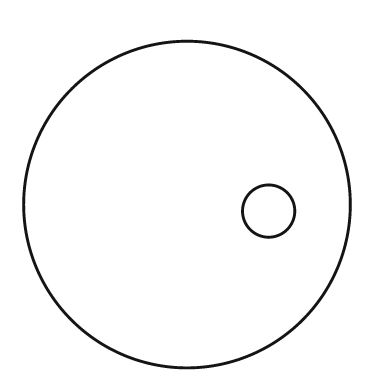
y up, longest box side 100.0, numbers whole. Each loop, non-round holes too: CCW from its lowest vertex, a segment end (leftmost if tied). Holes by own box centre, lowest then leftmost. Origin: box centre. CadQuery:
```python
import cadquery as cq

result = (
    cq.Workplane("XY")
    .moveTo(0.0, 0.0)
    .circle(50.0)
    .moveTo(25.0, -2.0)
    .circle(8.0)
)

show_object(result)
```